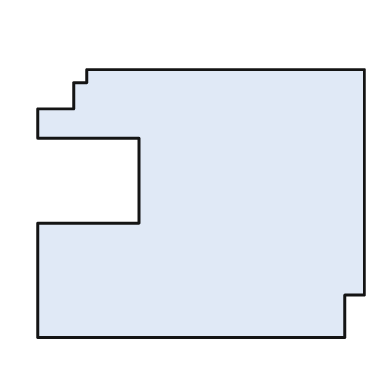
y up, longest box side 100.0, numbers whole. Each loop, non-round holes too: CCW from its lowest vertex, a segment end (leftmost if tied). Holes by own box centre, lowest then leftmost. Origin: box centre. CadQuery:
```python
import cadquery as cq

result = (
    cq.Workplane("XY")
    .moveTo(-50.0, -41.0)
    .lineTo(44.0, -41.0)
    .lineTo(44.0, -28.0)
    .lineTo(50.0, -28.0)
    .lineTo(50.0, 41.0)
    .lineTo(-35.0, 41.0)
    .lineTo(-35.0, 37.0)
    .lineTo(-39.0, 37.0)
    .lineTo(-39.0, 29.0)
    .lineTo(-50.0, 29.0)
    .lineTo(-50.0, 20.0)
    .lineTo(-19.0, 20.0)
    .lineTo(-19.0, -6.0)
    .lineTo(-50.0, -6.0)
    .close()
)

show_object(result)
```